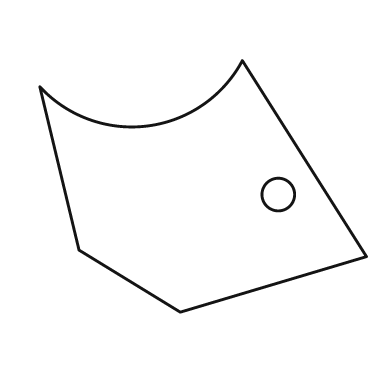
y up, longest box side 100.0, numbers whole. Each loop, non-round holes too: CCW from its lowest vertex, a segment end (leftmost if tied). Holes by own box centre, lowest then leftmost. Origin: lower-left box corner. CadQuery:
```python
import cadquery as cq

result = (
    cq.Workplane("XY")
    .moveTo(43.0, 0.0)
    .lineTo(100.0, 17.0)
    .lineTo(62.0, 77.0)
    .threePointArc((33.0, 57.0), (0.0, 69.0))
    .lineTo(12.0, 19.0)
    .close()
    .moveTo(73.0, 36.0)
    .circle(5.0)
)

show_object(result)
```